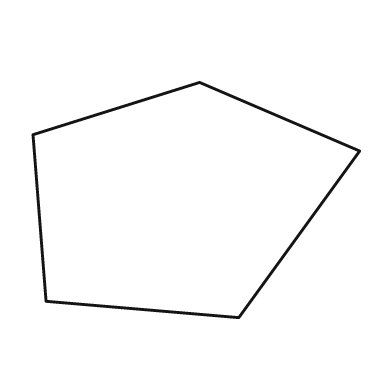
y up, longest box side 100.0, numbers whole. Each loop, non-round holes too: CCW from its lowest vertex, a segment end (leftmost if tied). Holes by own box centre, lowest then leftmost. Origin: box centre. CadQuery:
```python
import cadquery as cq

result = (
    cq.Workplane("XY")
    .moveTo(13.0, -36.0)
    .lineTo(50.0, 15.0)
    .lineTo(1.0, 36.0)
    .lineTo(-50.0, 20.0)
    .lineTo(-46.0, -31.0)
    .close()
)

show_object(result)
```